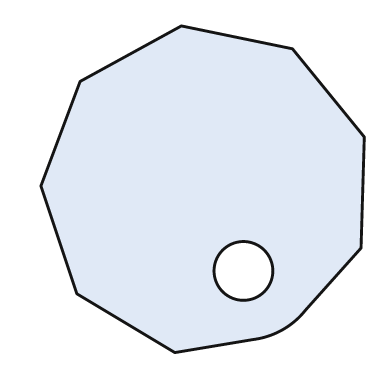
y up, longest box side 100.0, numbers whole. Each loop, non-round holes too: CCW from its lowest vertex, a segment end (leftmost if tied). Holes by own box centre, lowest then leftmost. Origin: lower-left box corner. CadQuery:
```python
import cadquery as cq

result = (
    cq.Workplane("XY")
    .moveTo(41.0, 0.0)
    .lineTo(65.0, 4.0)
    .threePointArc((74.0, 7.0), (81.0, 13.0))
    .lineTo(98.0, 32.0)
    .lineTo(99.0, 66.0)
    .lineTo(77.0, 93.0)
    .lineTo(43.0, 100.0)
    .lineTo(12.0, 83.0)
    .lineTo(0.0, 51.0)
    .lineTo(11.0, 18.0)
    .close()
    .moveTo(62.0, 25.0)
    .circle(9.0)
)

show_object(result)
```